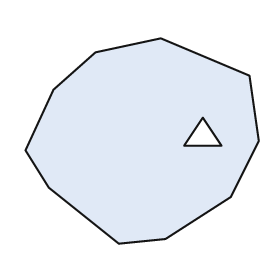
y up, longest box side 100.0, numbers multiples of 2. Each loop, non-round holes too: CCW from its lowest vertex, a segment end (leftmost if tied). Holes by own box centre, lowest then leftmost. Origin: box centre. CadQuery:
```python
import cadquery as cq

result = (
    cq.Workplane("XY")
    .moveTo(-10.0, -44.0)
    .lineTo(10.0, -42.0)
    .lineTo(38.0, -24.0)
    .lineTo(50.0, 0.0)
    .lineTo(46.0, 28.0)
    .lineTo(8.0, 44.0)
    .lineTo(-20.0, 38.0)
    .lineTo(-38.0, 22.0)
    .lineTo(-50.0, -4.0)
    .lineTo(-40.0, -20.0)
    .close()
    .moveTo(18.0, -2.0)
    .lineTo(34.0, -2.0)
    .lineTo(26.0, 10.0)
    .close()
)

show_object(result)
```